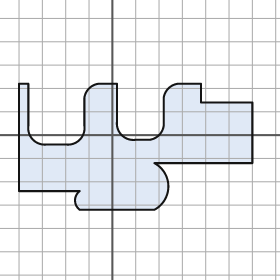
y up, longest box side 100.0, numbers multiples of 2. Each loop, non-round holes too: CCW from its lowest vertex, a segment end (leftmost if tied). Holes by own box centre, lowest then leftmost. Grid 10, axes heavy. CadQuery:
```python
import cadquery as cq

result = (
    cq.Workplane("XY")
    .moveTo(-14.0, -32.0)
    .lineTo(18.0, -32.0)
    .threePointArc((24.0, -22.0), (18.0, -12.0))
    .lineTo(60.0, -12.0)
    .lineTo(60.0, 14.0)
    .lineTo(38.0, 14.0)
    .lineTo(38.0, 22.0)
    .lineTo(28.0, 22.0)
    .threePointArc((24.0, 20.0), (22.0, 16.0))
    .lineTo(22.0, 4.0)
    .threePointArc((20.0, 0.0), (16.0, -2.0))
    .lineTo(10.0, -2.0)
    .threePointArc((4.0, 0.0), (2.0, 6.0))
    .lineTo(2.0, 22.0)
    .lineTo(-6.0, 22.0)
    .threePointArc((-10.0, 20.0), (-12.0, 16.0))
    .lineTo(-12.0, 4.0)
    .threePointArc((-14.0, -2.0), (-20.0, -4.0))
    .lineTo(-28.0, -4.0)
    .threePointArc((-34.0, -2.0), (-36.0, 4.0))
    .lineTo(-36.0, 22.0)
    .lineTo(-40.0, 22.0)
    .lineTo(-40.0, -24.0)
    .lineTo(-14.0, -24.0)
    .threePointArc((-16.0, -28.0), (-14.0, -32.0))
    .close()
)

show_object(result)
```